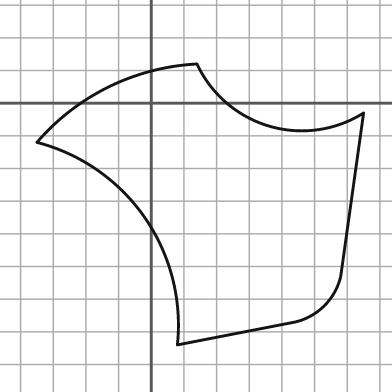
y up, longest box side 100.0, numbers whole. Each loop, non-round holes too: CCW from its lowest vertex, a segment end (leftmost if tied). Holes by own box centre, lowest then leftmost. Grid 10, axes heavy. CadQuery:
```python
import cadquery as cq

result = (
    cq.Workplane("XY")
    .moveTo(8.0, -74.0)
    .lineTo(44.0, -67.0)
    .threePointArc((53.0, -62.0), (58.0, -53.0))
    .lineTo(65.0, -3.0)
    .threePointArc((36.0, -7.0), (14.0, 12.0))
    .threePointArc((-13.0, 5.0), (-35.0, -12.0))
    .threePointArc((-2.0, -35.0), (8.0, -74.0))
    .close()
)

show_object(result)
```